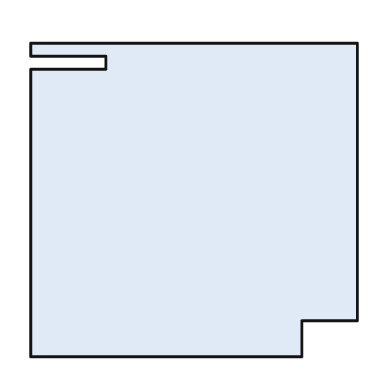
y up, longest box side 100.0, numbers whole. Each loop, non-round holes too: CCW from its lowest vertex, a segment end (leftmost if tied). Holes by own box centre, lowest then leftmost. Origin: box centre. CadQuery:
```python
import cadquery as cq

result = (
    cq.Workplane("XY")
    .moveTo(-50.0, -48.0)
    .lineTo(33.0, -48.0)
    .lineTo(33.0, -37.0)
    .lineTo(50.0, -37.0)
    .lineTo(50.0, 48.0)
    .lineTo(-50.0, 48.0)
    .lineTo(-50.0, 44.0)
    .lineTo(-27.0, 44.0)
    .lineTo(-27.0, 40.0)
    .lineTo(-50.0, 40.0)
    .close()
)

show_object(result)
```